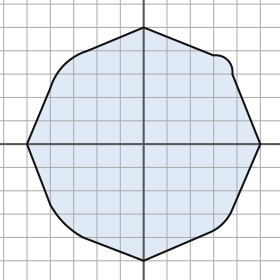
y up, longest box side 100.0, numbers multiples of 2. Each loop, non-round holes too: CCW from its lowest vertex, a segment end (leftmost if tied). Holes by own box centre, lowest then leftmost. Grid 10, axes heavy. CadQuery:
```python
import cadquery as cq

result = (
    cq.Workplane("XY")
    .moveTo(0.0, -50.0)
    .lineTo(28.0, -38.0)
    .threePointArc((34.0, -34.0), (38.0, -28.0))
    .lineTo(50.0, 0.0)
    .lineTo(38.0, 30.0)
    .threePointArc((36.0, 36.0), (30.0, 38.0))
    .lineTo(0.0, 50.0)
    .lineTo(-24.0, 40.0)
    .threePointArc((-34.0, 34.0), (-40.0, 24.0))
    .lineTo(-50.0, 0.0)
    .lineTo(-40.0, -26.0)
    .threePointArc((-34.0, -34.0), (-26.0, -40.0))
    .close()
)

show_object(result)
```